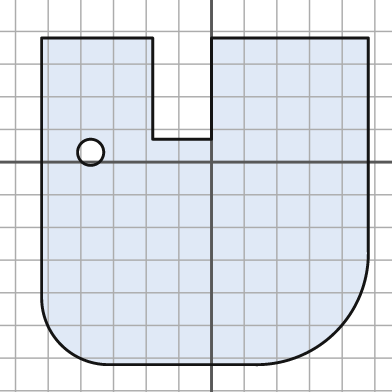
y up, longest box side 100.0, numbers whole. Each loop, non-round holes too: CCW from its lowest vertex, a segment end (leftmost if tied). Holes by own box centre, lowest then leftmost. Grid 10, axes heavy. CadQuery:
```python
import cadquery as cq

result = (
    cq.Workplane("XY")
    .moveTo(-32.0, -62.0)
    .lineTo(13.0, -62.0)
    .threePointArc((38.0, -52.0), (48.0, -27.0))
    .lineTo(48.0, 38.0)
    .lineTo(0.0, 38.0)
    .lineTo(0.0, 7.0)
    .lineTo(-18.0, 7.0)
    .lineTo(-18.0, 38.0)
    .lineTo(-52.0, 38.0)
    .lineTo(-52.0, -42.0)
    .threePointArc((-46.0, -56.0), (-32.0, -62.0))
    .close()
    .moveTo(-37.0, 3.0)
    .circle(4.0)
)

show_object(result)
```